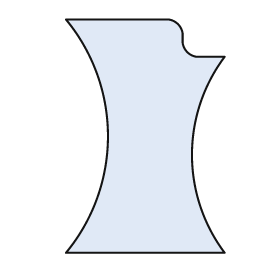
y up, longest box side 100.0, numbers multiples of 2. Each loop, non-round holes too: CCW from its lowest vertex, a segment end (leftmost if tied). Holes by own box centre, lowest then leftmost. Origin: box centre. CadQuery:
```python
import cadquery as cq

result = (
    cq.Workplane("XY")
    .moveTo(-34.0, -50.0)
    .lineTo(34.0, -50.0)
    .threePointArc((20.0, -8.0), (34.0, 34.0))
    .lineTo(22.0, 34.0)
    .threePointArc((18.0, 36.0), (16.0, 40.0))
    .lineTo(16.0, 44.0)
    .threePointArc((14.0, 48.0), (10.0, 50.0))
    .lineTo(-34.0, 50.0)
    .threePointArc((-16.0, 0.0), (-34.0, -50.0))
    .close()
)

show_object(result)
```